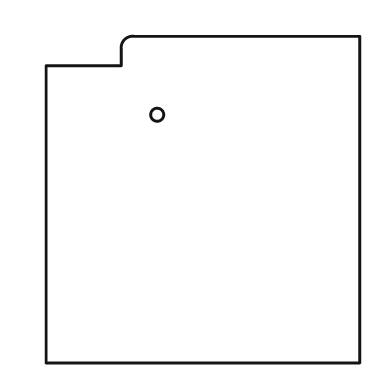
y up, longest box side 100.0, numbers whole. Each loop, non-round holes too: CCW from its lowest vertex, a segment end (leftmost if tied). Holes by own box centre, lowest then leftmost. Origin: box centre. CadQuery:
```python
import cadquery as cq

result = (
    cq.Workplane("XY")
    .moveTo(-48.0, -50.0)
    .lineTo(48.0, -50.0)
    .lineTo(48.0, 50.0)
    .lineTo(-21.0, 50.0)
    .threePointArc((-24.0, 49.0), (-25.0, 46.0))
    .lineTo(-25.0, 41.0)
    .lineTo(-48.0, 41.0)
    .close()
    .moveTo(-14.0, 26.0)
    .circle(2.0)
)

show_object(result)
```